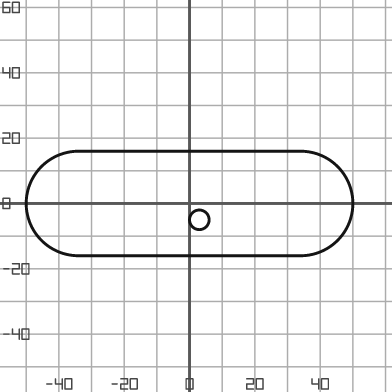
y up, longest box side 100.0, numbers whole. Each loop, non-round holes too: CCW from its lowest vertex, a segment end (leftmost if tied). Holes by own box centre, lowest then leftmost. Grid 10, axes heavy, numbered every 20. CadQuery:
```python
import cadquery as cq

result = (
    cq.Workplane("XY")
    .moveTo(-34.0, -16.0)
    .lineTo(34.0, -16.0)
    .threePointArc((50.0, 0.0), (34.0, 16.0))
    .lineTo(-34.0, 16.0)
    .threePointArc((-50.0, 0.0), (-34.0, -16.0))
    .close()
    .moveTo(3.0, -5.0)
    .circle(3.0)
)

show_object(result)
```